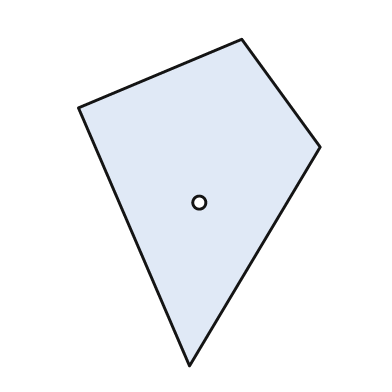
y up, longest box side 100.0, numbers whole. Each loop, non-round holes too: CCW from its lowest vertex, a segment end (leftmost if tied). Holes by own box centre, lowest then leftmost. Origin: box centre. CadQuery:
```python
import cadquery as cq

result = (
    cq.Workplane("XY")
    .moveTo(-3.0, -50.0)
    .lineTo(37.0, 17.0)
    .lineTo(13.0, 50.0)
    .lineTo(-37.0, 29.0)
    .close()
    .moveTo(0.0, 0.0)
    .circle(2.0)
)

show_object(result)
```